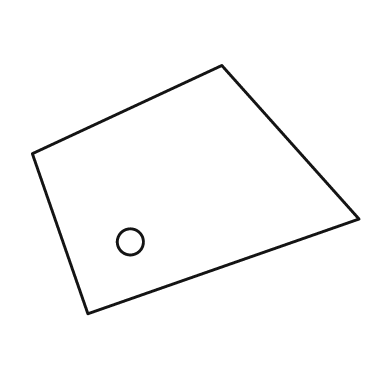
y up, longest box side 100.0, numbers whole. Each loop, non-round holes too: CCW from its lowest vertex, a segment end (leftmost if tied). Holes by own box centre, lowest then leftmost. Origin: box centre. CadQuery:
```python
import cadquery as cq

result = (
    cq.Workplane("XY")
    .moveTo(-33.0, -38.0)
    .lineTo(50.0, -9.0)
    .lineTo(8.0, 38.0)
    .lineTo(-50.0, 11.0)
    .close()
    .moveTo(-20.0, -16.0)
    .circle(4.0)
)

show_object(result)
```